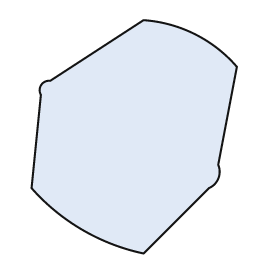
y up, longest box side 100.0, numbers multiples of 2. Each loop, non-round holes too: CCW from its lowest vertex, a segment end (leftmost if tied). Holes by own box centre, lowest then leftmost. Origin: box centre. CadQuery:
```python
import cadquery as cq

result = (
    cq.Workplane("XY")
    .moveTo(4.0, -50.0)
    .lineTo(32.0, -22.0)
    .threePointArc((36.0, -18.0), (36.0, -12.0))
    .lineTo(44.0, 30.0)
    .threePointArc((26.0, 44.0), (4.0, 50.0))
    .lineTo(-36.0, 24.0)
    .threePointArc((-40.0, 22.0), (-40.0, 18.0))
    .lineTo(-44.0, -22.0)
    .threePointArc((-22.0, -40.0), (4.0, -50.0))
    .close()
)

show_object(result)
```